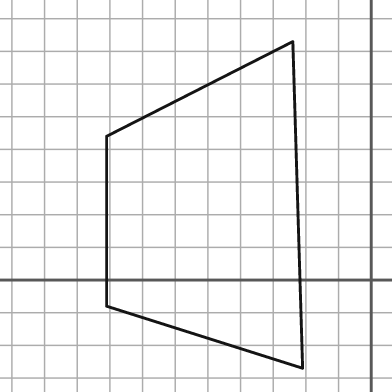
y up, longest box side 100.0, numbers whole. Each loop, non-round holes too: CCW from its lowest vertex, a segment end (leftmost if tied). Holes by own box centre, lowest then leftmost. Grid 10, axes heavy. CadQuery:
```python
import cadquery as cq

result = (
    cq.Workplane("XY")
    .moveTo(-21.0, -27.0)
    .lineTo(-24.0, 73.0)
    .lineTo(-81.0, 44.0)
    .lineTo(-81.0, -8.0)
    .close()
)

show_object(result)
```